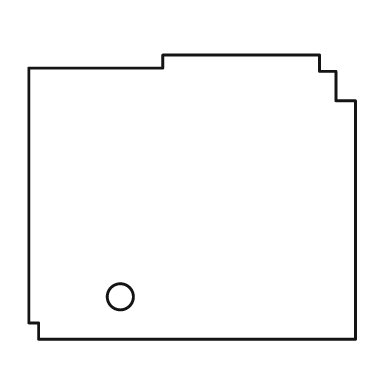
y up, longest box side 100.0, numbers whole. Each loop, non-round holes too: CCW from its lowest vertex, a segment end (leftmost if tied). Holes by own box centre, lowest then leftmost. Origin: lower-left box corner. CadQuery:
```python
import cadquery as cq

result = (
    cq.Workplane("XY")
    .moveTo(3.0, 0.0)
    .lineTo(100.0, 0.0)
    .lineTo(100.0, 73.0)
    .lineTo(94.0, 73.0)
    .lineTo(94.0, 82.0)
    .lineTo(89.0, 82.0)
    .lineTo(89.0, 87.0)
    .lineTo(41.0, 87.0)
    .lineTo(41.0, 83.0)
    .lineTo(0.0, 83.0)
    .lineTo(0.0, 5.0)
    .lineTo(3.0, 5.0)
    .close()
    .moveTo(28.0, 13.0)
    .circle(4.0)
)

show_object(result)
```